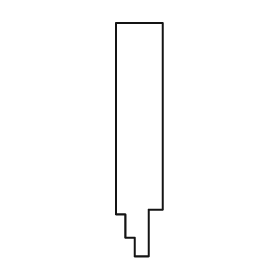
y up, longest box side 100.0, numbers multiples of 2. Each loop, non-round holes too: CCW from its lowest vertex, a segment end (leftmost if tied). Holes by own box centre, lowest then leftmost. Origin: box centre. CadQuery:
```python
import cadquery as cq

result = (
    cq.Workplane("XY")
    .moveTo(-2.0, -50.0)
    .lineTo(4.0, -50.0)
    .lineTo(4.0, -30.0)
    .lineTo(10.0, -30.0)
    .lineTo(10.0, 50.0)
    .lineTo(-10.0, 50.0)
    .lineTo(-10.0, -32.0)
    .lineTo(-6.0, -32.0)
    .lineTo(-6.0, -42.0)
    .lineTo(-2.0, -42.0)
    .close()
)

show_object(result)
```